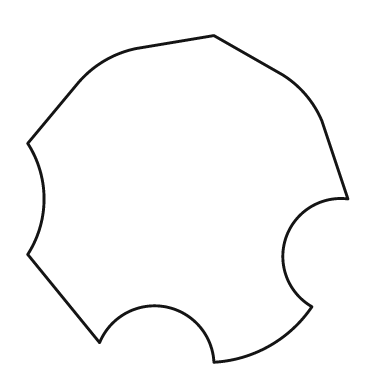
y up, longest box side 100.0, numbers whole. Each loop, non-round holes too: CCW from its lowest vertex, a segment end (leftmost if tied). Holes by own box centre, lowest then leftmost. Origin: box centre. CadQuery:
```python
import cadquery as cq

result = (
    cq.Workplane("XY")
    .moveTo(8.0, -50.0)
    .threePointArc((25.0, -45.0), (38.0, -33.0))
    .threePointArc((30.0, -12.0), (49.0, 0.0))
    .lineTo(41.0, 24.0)
    .threePointArc((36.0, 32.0), (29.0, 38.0))
    .lineTo(8.0, 50.0)
    .lineTo(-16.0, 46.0)
    .threePointArc((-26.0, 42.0), (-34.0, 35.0))
    .lineTo(-49.0, 17.0)
    .threePointArc((-44.0, 0.0), (-49.0, -17.0))
    .lineTo(-27.0, -44.0)
    .threePointArc((-7.0, -33.0), (8.0, -50.0))
    .close()
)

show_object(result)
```